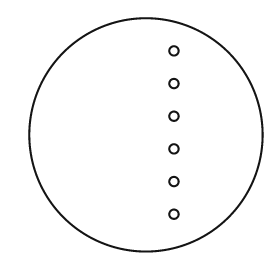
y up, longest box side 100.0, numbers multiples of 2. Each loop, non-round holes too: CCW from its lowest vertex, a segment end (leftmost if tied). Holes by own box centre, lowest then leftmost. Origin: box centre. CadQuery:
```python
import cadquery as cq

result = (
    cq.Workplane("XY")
    .moveTo(0.0, 0.0)
    .circle(50.0)
    .moveTo(12.0, -34.0)
    .circle(2.0)
    .moveTo(12.0, -20.0)
    .circle(2.0)
    .moveTo(12.0, -6.0)
    .circle(2.0)
    .moveTo(12.0, 8.0)
    .circle(2.0)
    .moveTo(12.0, 22.0)
    .circle(2.0)
    .moveTo(12.0, 36.0)
    .circle(2.0)
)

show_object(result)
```